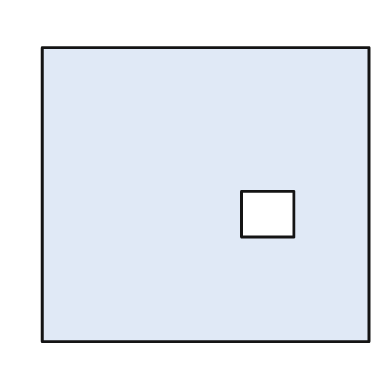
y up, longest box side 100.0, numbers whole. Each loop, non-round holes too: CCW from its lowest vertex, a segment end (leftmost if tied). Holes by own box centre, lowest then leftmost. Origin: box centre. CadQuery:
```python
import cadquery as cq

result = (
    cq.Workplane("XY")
    .moveTo(-50.0, -45.0)
    .lineTo(50.0, -45.0)
    .lineTo(50.0, 45.0)
    .lineTo(-50.0, 45.0)
    .close()
    .moveTo(11.0, -13.0)
    .lineTo(27.0, -13.0)
    .lineTo(27.0, 1.0)
    .lineTo(11.0, 1.0)
    .close()
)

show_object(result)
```